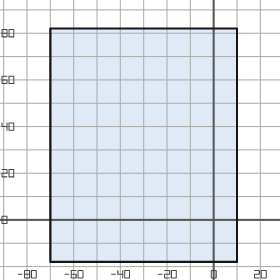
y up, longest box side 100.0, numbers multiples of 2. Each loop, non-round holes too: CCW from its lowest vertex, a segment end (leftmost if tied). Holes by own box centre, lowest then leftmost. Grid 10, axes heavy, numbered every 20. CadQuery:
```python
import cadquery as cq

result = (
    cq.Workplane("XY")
    .moveTo(-70.0, -18.0)
    .lineTo(10.0, -18.0)
    .lineTo(10.0, 82.0)
    .lineTo(-70.0, 82.0)
    .close()
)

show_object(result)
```